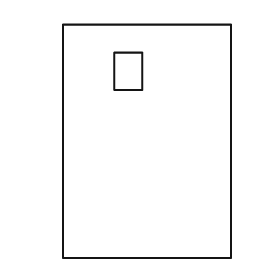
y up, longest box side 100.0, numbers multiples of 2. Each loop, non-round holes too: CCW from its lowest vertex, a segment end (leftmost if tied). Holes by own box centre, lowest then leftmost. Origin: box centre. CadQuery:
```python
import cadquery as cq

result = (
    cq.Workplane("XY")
    .moveTo(-36.0, -50.0)
    .lineTo(36.0, -50.0)
    .lineTo(36.0, 50.0)
    .lineTo(-36.0, 50.0)
    .close()
    .moveTo(-14.0, 22.0)
    .lineTo(-2.0, 22.0)
    .lineTo(-2.0, 38.0)
    .lineTo(-14.0, 38.0)
    .close()
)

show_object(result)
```